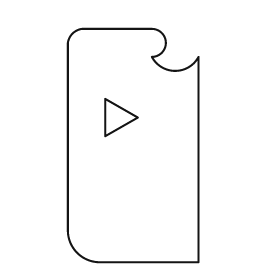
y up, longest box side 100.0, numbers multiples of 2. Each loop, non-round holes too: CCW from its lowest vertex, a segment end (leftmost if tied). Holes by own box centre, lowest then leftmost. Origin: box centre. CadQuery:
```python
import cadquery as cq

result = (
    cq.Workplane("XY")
    .moveTo(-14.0, -50.0)
    .lineTo(28.0, -50.0)
    .lineTo(28.0, 38.0)
    .threePointArc((18.0, 32.0), (8.0, 38.0))
    .threePointArc((14.0, 44.0), (8.0, 50.0))
    .lineTo(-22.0, 50.0)
    .threePointArc((-26.0, 48.0), (-28.0, 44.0))
    .lineTo(-28.0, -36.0)
    .threePointArc((-24.0, -46.0), (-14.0, -50.0))
    .close()
    .moveTo(-12.0, 4.0)
    .lineTo(2.0, 12.0)
    .lineTo(-12.0, 20.0)
    .close()
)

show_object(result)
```